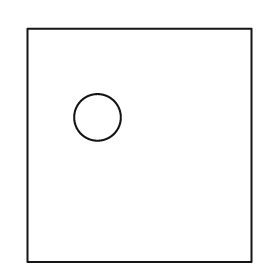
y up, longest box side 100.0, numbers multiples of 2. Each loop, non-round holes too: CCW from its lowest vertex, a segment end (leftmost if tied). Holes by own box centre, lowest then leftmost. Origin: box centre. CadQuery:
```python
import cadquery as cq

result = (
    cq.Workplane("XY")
    .moveTo(-48.0, -50.0)
    .lineTo(48.0, -50.0)
    .lineTo(48.0, 50.0)
    .lineTo(-48.0, 50.0)
    .close()
    .moveTo(-18.0, 12.0)
    .circle(10.0)
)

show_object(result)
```